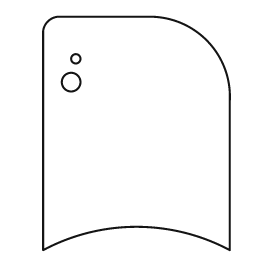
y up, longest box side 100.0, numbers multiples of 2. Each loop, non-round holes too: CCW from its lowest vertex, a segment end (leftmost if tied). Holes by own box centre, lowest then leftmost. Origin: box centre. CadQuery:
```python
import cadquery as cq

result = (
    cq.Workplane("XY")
    .moveTo(-40.0, -50.0)
    .threePointArc((0.0, -40.0), (40.0, -50.0))
    .lineTo(40.0, 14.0)
    .threePointArc((30.0, 40.0), (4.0, 50.0))
    .lineTo(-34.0, 50.0)
    .threePointArc((-38.0, 48.0), (-40.0, 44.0))
    .close()
    .moveTo(-28.0, 22.0)
    .circle(4.0)
    .moveTo(-26.0, 32.0)
    .circle(2.0)
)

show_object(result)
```